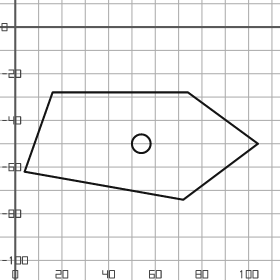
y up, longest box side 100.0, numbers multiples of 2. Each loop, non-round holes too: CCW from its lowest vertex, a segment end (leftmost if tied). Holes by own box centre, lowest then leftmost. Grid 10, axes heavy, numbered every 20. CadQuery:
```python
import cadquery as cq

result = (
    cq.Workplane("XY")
    .moveTo(72.0, -74.0)
    .lineTo(104.0, -50.0)
    .lineTo(74.0, -28.0)
    .lineTo(16.0, -28.0)
    .lineTo(4.0, -62.0)
    .close()
    .moveTo(54.0, -50.0)
    .circle(4.0)
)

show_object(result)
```